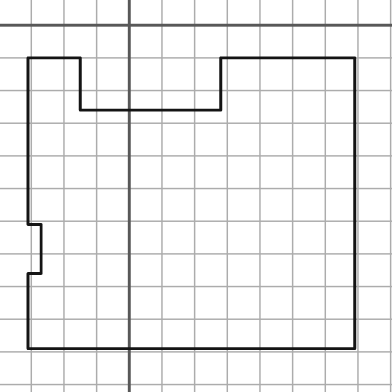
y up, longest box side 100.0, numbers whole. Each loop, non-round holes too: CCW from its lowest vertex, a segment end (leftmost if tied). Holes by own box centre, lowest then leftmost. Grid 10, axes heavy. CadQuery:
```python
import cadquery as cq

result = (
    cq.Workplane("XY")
    .moveTo(-31.0, -99.0)
    .lineTo(69.0, -99.0)
    .lineTo(69.0, -10.0)
    .lineTo(28.0, -10.0)
    .lineTo(28.0, -26.0)
    .lineTo(-15.0, -26.0)
    .lineTo(-15.0, -10.0)
    .lineTo(-31.0, -10.0)
    .lineTo(-31.0, -61.0)
    .lineTo(-27.0, -61.0)
    .lineTo(-27.0, -76.0)
    .lineTo(-31.0, -76.0)
    .close()
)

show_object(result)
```